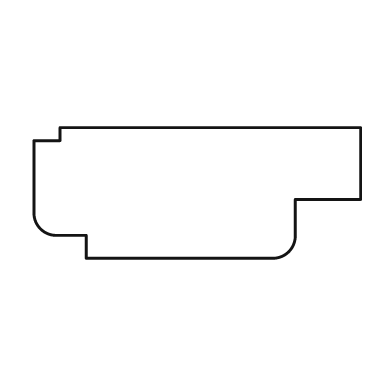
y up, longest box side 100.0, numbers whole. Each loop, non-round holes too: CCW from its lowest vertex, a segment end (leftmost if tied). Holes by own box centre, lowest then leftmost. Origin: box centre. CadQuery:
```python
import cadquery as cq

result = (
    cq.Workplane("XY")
    .moveTo(-34.0, -20.0)
    .lineTo(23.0, -20.0)
    .threePointArc((28.0, -18.0), (30.0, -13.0))
    .lineTo(30.0, -2.0)
    .lineTo(50.0, -2.0)
    .lineTo(50.0, 20.0)
    .lineTo(-42.0, 20.0)
    .lineTo(-42.0, 16.0)
    .lineTo(-50.0, 16.0)
    .lineTo(-50.0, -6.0)
    .threePointArc((-48.0, -11.0), (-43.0, -13.0))
    .lineTo(-34.0, -13.0)
    .close()
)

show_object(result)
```